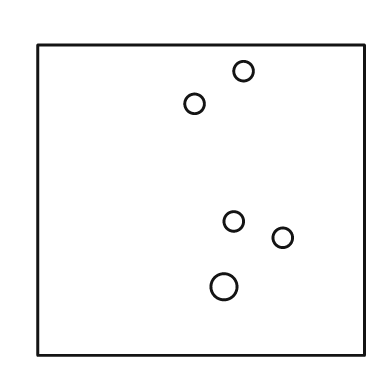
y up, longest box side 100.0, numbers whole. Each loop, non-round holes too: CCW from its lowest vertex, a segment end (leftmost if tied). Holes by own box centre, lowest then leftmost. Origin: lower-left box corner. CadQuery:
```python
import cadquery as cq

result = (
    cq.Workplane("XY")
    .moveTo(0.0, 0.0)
    .lineTo(100.0, 0.0)
    .lineTo(100.0, 95.0)
    .lineTo(0.0, 95.0)
    .close()
    .moveTo(57.0, 21.0)
    .circle(4.0)
    .moveTo(75.0, 36.0)
    .circle(3.0)
    .moveTo(60.0, 41.0)
    .circle(3.0)
    .moveTo(48.0, 77.0)
    .circle(3.0)
    .moveTo(63.0, 87.0)
    .circle(3.0)
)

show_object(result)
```